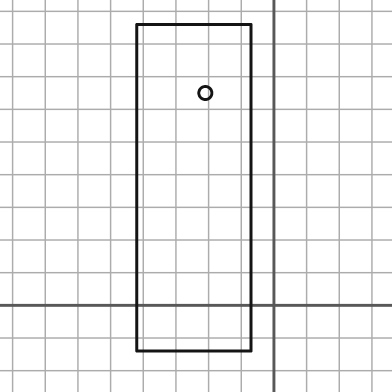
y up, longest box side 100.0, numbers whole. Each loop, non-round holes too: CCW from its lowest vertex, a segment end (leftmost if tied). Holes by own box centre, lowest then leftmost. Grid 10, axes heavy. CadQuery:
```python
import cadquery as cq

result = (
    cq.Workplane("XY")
    .moveTo(-42.0, -14.0)
    .lineTo(-7.0, -14.0)
    .lineTo(-7.0, 86.0)
    .lineTo(-42.0, 86.0)
    .close()
    .moveTo(-21.0, 65.0)
    .circle(2.0)
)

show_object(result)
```